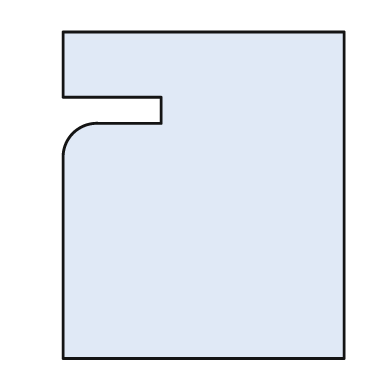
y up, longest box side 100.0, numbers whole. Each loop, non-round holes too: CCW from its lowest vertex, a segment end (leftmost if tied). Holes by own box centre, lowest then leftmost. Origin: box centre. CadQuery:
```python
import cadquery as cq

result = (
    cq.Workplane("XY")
    .moveTo(-43.0, -50.0)
    .lineTo(43.0, -50.0)
    .lineTo(43.0, 50.0)
    .lineTo(-43.0, 50.0)
    .lineTo(-43.0, 30.0)
    .lineTo(-13.0, 30.0)
    .lineTo(-13.0, 22.0)
    .lineTo(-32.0, 22.0)
    .threePointArc((-40.0, 19.0), (-43.0, 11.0))
    .close()
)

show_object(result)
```